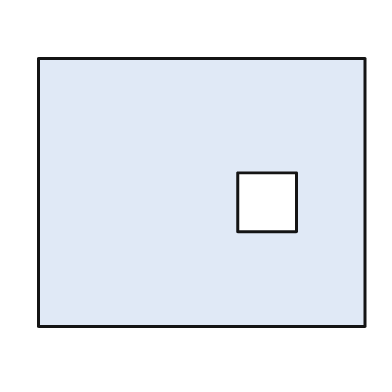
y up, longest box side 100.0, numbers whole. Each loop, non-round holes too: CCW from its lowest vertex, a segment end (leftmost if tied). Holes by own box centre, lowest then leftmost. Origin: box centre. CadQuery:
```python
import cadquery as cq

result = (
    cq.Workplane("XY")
    .moveTo(-50.0, -41.0)
    .lineTo(50.0, -41.0)
    .lineTo(50.0, 41.0)
    .lineTo(-50.0, 41.0)
    .close()
    .moveTo(11.0, -12.0)
    .lineTo(29.0, -12.0)
    .lineTo(29.0, 6.0)
    .lineTo(11.0, 6.0)
    .close()
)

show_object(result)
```